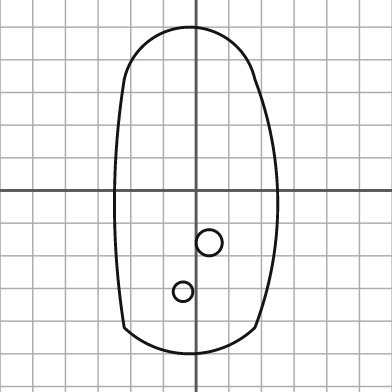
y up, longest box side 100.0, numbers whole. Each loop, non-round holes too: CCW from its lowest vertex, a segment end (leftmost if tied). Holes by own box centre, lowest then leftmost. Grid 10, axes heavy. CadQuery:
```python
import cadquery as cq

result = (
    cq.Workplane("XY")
    .moveTo(-22.0, -42.0)
    .threePointArc((-2.0, -50.0), (18.0, -42.0))
    .threePointArc((25.0, -4.0), (18.0, 34.0))
    .threePointArc((-2.0, 50.0), (-22.0, 34.0))
    .threePointArc((-25.0, -4.0), (-22.0, -42.0))
    .close()
    .moveTo(-4.0, -31.0)
    .circle(3.0)
    .moveTo(4.0, -16.0)
    .circle(4.0)
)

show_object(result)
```